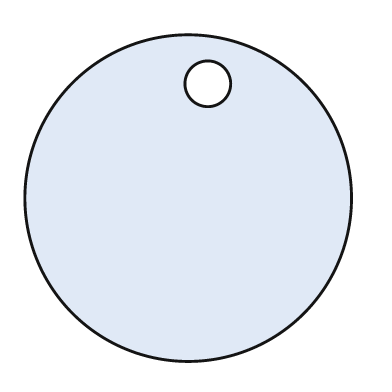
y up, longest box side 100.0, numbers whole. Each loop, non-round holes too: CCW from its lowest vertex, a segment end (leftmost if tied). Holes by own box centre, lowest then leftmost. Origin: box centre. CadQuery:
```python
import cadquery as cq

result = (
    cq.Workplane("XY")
    .moveTo(0.0, 0.0)
    .circle(50.0)
    .moveTo(6.0, 35.0)
    .circle(7.0)
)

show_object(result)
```